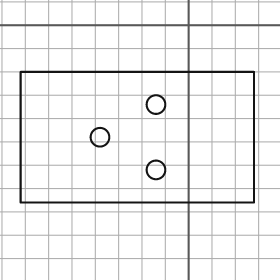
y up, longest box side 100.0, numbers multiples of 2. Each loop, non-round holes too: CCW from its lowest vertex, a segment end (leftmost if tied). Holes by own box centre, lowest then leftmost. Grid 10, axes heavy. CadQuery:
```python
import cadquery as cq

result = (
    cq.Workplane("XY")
    .moveTo(-72.0, -76.0)
    .lineTo(28.0, -76.0)
    .lineTo(28.0, -20.0)
    .lineTo(-72.0, -20.0)
    .close()
    .moveTo(-14.0, -62.0)
    .circle(4.0)
    .moveTo(-38.0, -48.0)
    .circle(4.0)
    .moveTo(-14.0, -34.0)
    .circle(4.0)
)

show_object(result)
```